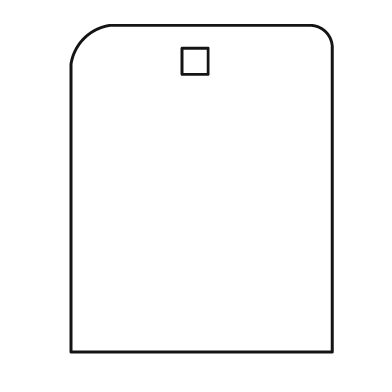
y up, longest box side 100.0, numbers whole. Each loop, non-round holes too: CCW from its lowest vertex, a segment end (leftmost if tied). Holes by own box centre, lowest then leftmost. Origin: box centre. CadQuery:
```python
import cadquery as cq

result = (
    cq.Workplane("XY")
    .moveTo(-40.0, -50.0)
    .lineTo(40.0, -50.0)
    .lineTo(40.0, 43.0)
    .threePointArc((38.0, 48.0), (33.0, 50.0))
    .lineTo(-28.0, 50.0)
    .threePointArc((-36.0, 46.0), (-40.0, 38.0))
    .close()
    .moveTo(-6.0, 35.0)
    .lineTo(2.0, 35.0)
    .lineTo(2.0, 43.0)
    .lineTo(-6.0, 43.0)
    .close()
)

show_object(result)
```